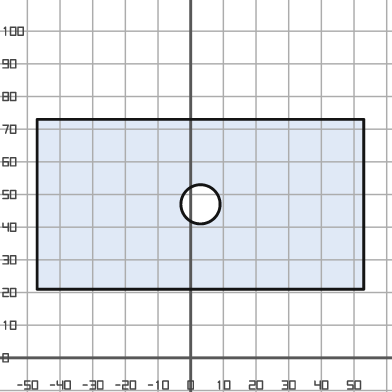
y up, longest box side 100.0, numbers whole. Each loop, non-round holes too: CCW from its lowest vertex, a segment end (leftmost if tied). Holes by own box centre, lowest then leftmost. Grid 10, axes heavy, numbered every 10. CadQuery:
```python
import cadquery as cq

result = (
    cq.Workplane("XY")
    .moveTo(-47.0, 21.0)
    .lineTo(53.0, 21.0)
    .lineTo(53.0, 73.0)
    .lineTo(-47.0, 73.0)
    .close()
    .moveTo(3.0, 47.0)
    .circle(6.0)
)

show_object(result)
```